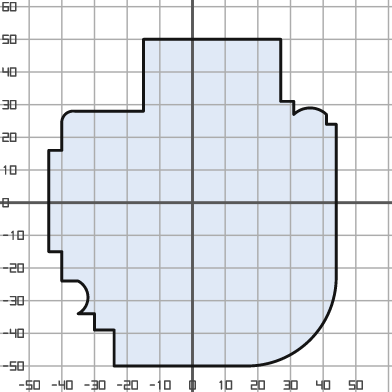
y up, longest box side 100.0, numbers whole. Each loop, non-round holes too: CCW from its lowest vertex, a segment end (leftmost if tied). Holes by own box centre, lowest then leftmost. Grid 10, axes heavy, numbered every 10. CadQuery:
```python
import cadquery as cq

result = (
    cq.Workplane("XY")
    .moveTo(-24.0, -50.0)
    .lineTo(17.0, -50.0)
    .threePointArc((36.0, -42.0), (44.0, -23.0))
    .lineTo(44.0, 24.0)
    .lineTo(41.0, 24.0)
    .lineTo(41.0, 27.0)
    .threePointArc((36.0, 29.0), (31.0, 27.0))
    .lineTo(31.0, 31.0)
    .lineTo(27.0, 31.0)
    .lineTo(27.0, 50.0)
    .lineTo(-15.0, 50.0)
    .lineTo(-15.0, 28.0)
    .lineTo(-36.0, 28.0)
    .threePointArc((-39.0, 27.0), (-40.0, 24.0))
    .lineTo(-40.0, 16.0)
    .lineTo(-44.0, 16.0)
    .lineTo(-44.0, -15.0)
    .lineTo(-40.0, -15.0)
    .lineTo(-40.0, -24.0)
    .lineTo(-35.0, -24.0)
    .threePointArc((-32.0, -29.0), (-35.0, -34.0))
    .lineTo(-30.0, -34.0)
    .lineTo(-30.0, -39.0)
    .lineTo(-24.0, -39.0)
    .close()
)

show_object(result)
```